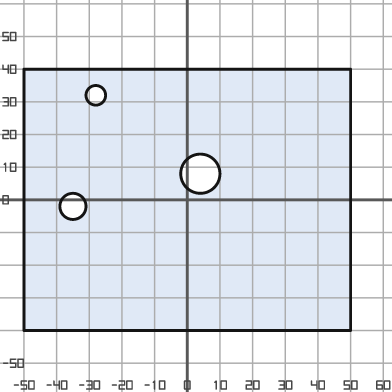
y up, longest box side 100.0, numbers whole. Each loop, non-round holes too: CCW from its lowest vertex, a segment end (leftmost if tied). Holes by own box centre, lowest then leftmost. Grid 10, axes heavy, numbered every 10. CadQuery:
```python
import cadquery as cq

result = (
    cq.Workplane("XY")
    .moveTo(-50.0, -40.0)
    .lineTo(50.0, -40.0)
    .lineTo(50.0, 40.0)
    .lineTo(-50.0, 40.0)
    .close()
    .moveTo(-35.0, -2.0)
    .circle(4.0)
    .moveTo(4.0, 8.0)
    .circle(6.0)
    .moveTo(-28.0, 32.0)
    .circle(3.0)
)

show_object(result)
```